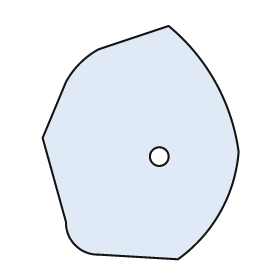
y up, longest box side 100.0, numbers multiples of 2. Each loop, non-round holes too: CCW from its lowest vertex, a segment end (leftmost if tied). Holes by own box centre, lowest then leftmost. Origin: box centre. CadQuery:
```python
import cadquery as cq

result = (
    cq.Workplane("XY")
    .moveTo(16.0, -50.0)
    .threePointArc((34.0, -30.0), (42.0, -4.0))
    .threePointArc((32.0, 26.0), (12.0, 50.0))
    .lineTo(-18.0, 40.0)
    .threePointArc((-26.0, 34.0), (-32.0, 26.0))
    .lineTo(-42.0, 2.0)
    .lineTo(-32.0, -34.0)
    .threePointArc((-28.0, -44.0), (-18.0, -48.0))
    .close()
    .moveTo(8.0, -6.0)
    .circle(4.0)
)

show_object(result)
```